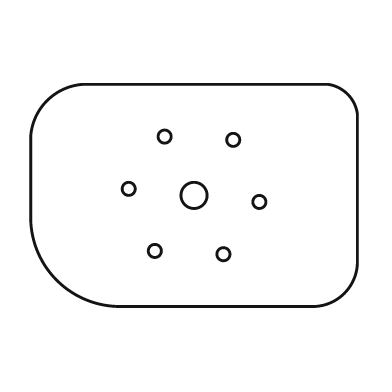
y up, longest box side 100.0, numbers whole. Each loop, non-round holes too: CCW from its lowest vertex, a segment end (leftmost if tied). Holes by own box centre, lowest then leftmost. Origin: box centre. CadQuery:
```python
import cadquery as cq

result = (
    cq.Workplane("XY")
    .moveTo(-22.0, -34.0)
    .lineTo(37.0, -34.0)
    .threePointArc((46.0, -30.0), (50.0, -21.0))
    .lineTo(50.0, 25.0)
    .threePointArc((47.0, 31.0), (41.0, 34.0))
    .lineTo(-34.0, 34.0)
    .threePointArc((-45.0, 29.0), (-50.0, 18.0))
    .lineTo(-50.0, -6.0)
    .threePointArc((-42.0, -26.0), (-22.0, -34.0))
    .close()
    .moveTo(9.0, -18.0)
    .circle(2.0)
    .moveTo(-12.0, -17.0)
    .circle(2.0)
    .moveTo(20.0, -2.0)
    .circle(2.0)
    .moveTo(0.0, 0.0)
    .circle(4.0)
    .moveTo(-20.0, 2.0)
    .circle(2.0)
    .moveTo(12.0, 17.0)
    .circle(2.0)
    .moveTo(-9.0, 18.0)
    .circle(2.0)
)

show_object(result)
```